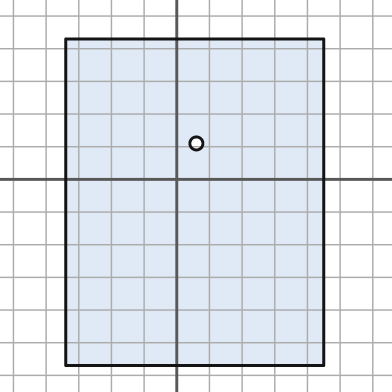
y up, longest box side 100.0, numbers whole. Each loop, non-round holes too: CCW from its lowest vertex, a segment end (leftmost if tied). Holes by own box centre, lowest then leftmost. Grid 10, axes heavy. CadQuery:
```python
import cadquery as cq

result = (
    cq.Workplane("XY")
    .moveTo(-34.0, -57.0)
    .lineTo(45.0, -57.0)
    .lineTo(45.0, 43.0)
    .lineTo(-34.0, 43.0)
    .close()
    .moveTo(6.0, 11.0)
    .circle(2.0)
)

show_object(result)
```